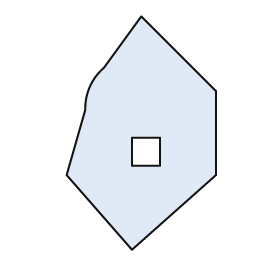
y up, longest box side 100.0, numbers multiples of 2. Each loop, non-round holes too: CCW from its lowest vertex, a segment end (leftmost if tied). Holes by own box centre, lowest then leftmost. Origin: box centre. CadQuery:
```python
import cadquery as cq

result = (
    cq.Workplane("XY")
    .moveTo(-4.0, -50.0)
    .lineTo(32.0, -18.0)
    .lineTo(32.0, 18.0)
    .lineTo(0.0, 50.0)
    .lineTo(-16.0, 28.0)
    .threePointArc((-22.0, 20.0), (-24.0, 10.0))
    .lineTo(-32.0, -18.0)
    .close()
    .moveTo(-4.0, -14.0)
    .lineTo(8.0, -14.0)
    .lineTo(8.0, -2.0)
    .lineTo(-4.0, -2.0)
    .close()
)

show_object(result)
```